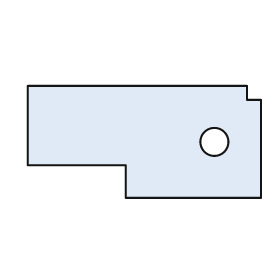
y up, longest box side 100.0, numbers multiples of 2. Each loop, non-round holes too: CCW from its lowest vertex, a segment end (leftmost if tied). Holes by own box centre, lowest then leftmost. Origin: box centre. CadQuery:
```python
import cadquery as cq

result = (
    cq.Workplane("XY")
    .moveTo(-8.0, -24.0)
    .lineTo(50.0, -24.0)
    .lineTo(50.0, 18.0)
    .lineTo(44.0, 18.0)
    .lineTo(44.0, 24.0)
    .lineTo(-50.0, 24.0)
    .lineTo(-50.0, -10.0)
    .lineTo(-8.0, -10.0)
    .close()
    .moveTo(30.0, 0.0)
    .circle(6.0)
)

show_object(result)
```